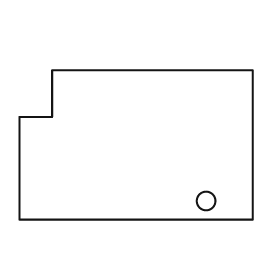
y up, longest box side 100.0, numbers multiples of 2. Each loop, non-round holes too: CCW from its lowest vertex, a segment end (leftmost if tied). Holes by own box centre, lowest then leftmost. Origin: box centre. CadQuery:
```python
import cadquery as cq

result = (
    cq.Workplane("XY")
    .moveTo(-50.0, -32.0)
    .lineTo(50.0, -32.0)
    .lineTo(50.0, 32.0)
    .lineTo(-36.0, 32.0)
    .lineTo(-36.0, 12.0)
    .lineTo(-50.0, 12.0)
    .close()
    .moveTo(30.0, -24.0)
    .circle(4.0)
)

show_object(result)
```